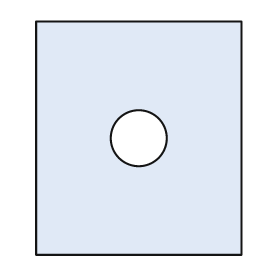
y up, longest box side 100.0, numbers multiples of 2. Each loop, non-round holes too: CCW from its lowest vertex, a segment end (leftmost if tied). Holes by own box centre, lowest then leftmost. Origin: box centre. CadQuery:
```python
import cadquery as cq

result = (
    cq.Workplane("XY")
    .moveTo(-44.0, -50.0)
    .lineTo(44.0, -50.0)
    .lineTo(44.0, 50.0)
    .lineTo(-44.0, 50.0)
    .close()
    .moveTo(0.0, 0.0)
    .circle(12.0)
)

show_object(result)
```